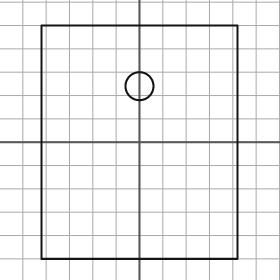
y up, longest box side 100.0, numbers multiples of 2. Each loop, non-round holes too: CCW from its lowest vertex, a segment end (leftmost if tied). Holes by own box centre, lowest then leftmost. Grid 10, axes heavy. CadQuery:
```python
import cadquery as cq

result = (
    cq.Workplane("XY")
    .moveTo(-42.0, -50.0)
    .lineTo(42.0, -50.0)
    .lineTo(42.0, 50.0)
    .lineTo(-42.0, 50.0)
    .close()
    .moveTo(0.0, 24.0)
    .circle(6.0)
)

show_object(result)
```